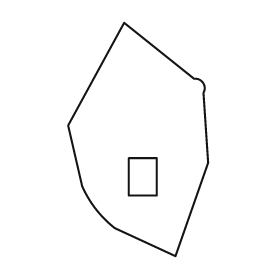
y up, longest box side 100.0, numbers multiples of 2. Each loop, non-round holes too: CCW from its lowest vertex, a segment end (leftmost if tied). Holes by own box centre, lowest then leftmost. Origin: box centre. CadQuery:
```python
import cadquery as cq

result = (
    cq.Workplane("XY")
    .moveTo(16.0, -50.0)
    .lineTo(30.0, -10.0)
    .lineTo(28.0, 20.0)
    .threePointArc((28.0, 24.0), (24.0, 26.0))
    .lineTo(-6.0, 50.0)
    .lineTo(-30.0, 6.0)
    .lineTo(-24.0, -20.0)
    .threePointArc((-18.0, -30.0), (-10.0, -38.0))
    .close()
    .moveTo(-4.0, -24.0)
    .lineTo(8.0, -24.0)
    .lineTo(8.0, -8.0)
    .lineTo(-4.0, -8.0)
    .close()
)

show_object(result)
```